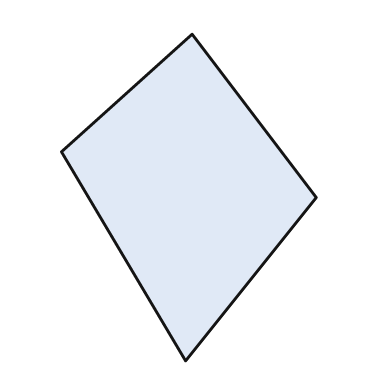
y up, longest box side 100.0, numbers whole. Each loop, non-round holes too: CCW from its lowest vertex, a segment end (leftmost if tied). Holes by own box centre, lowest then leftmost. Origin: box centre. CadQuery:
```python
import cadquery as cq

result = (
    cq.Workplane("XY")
    .moveTo(-1.0, -50.0)
    .lineTo(39.0, 0.0)
    .lineTo(1.0, 50.0)
    .lineTo(-39.0, 14.0)
    .close()
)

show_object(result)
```